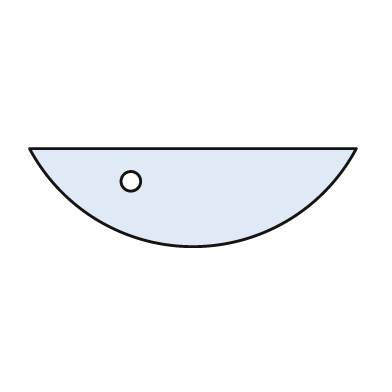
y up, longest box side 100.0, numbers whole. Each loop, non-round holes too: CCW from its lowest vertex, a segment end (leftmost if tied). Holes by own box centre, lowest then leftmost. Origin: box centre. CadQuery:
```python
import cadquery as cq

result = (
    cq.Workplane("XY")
    .moveTo(-50.0, 15.0)
    .threePointArc((0.0, -15.0), (50.0, 15.0))
    .close()
    .moveTo(-19.0, 5.0)
    .circle(3.0)
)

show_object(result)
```